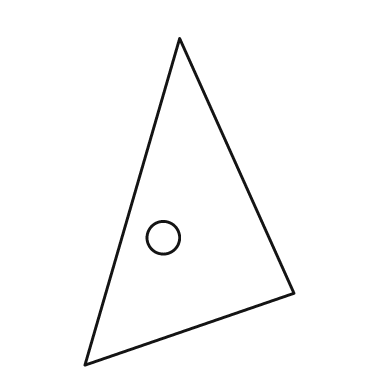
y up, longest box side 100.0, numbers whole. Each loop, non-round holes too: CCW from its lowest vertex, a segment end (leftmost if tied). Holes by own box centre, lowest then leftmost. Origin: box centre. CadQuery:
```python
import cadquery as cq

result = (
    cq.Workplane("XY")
    .moveTo(-32.0, -50.0)
    .lineTo(32.0, -28.0)
    .lineTo(-3.0, 50.0)
    .close()
    .moveTo(-8.0, -11.0)
    .circle(5.0)
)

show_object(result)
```